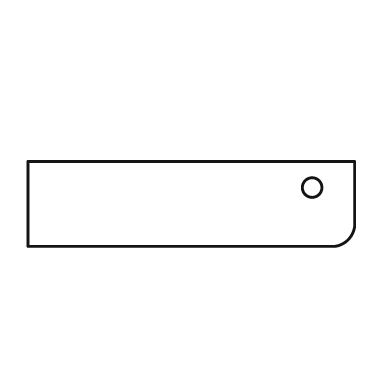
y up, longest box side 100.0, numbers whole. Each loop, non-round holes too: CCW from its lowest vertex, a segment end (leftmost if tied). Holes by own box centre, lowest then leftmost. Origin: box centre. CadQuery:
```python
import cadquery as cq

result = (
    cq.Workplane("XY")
    .moveTo(-50.0, -13.0)
    .lineTo(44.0, -13.0)
    .threePointArc((48.0, -11.0), (50.0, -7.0))
    .lineTo(50.0, 13.0)
    .lineTo(-50.0, 13.0)
    .close()
    .moveTo(37.0, 5.0)
    .circle(3.0)
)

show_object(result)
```